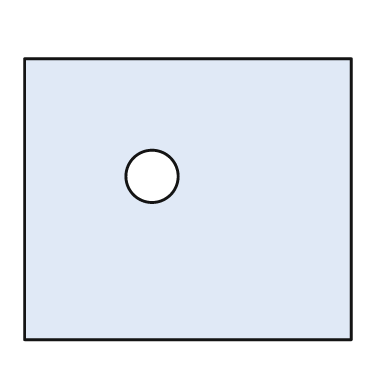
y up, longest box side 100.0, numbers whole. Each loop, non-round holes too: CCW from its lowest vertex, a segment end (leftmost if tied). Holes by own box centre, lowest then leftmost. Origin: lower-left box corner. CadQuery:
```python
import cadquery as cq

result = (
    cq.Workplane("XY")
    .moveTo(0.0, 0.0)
    .lineTo(100.0, 0.0)
    .lineTo(100.0, 86.0)
    .lineTo(0.0, 86.0)
    .close()
    .moveTo(39.0, 50.0)
    .circle(8.0)
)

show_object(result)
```